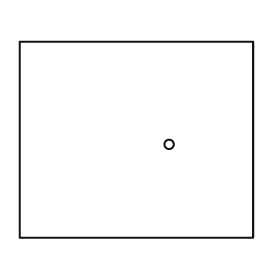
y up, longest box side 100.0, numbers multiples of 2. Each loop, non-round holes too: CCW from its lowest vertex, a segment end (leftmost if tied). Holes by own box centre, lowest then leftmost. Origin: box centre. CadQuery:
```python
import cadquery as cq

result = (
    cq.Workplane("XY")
    .moveTo(-50.0, -42.0)
    .lineTo(50.0, -42.0)
    .lineTo(50.0, 42.0)
    .lineTo(-50.0, 42.0)
    .close()
    .moveTo(14.0, -2.0)
    .circle(2.0)
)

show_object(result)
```